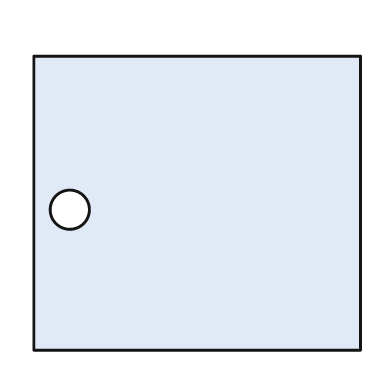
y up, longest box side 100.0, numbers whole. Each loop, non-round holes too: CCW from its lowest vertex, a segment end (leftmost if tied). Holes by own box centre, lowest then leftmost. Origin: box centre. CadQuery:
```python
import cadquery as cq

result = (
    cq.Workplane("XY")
    .moveTo(-50.0, -45.0)
    .lineTo(50.0, -45.0)
    .lineTo(50.0, 45.0)
    .lineTo(-50.0, 45.0)
    .close()
    .moveTo(-39.0, -2.0)
    .circle(6.0)
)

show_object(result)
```